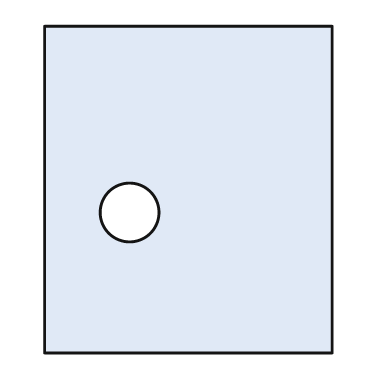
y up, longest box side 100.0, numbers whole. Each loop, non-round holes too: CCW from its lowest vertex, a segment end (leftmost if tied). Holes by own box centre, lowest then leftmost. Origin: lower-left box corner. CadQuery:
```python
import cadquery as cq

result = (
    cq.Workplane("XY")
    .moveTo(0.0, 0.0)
    .lineTo(88.0, 0.0)
    .lineTo(88.0, 100.0)
    .lineTo(0.0, 100.0)
    .close()
    .moveTo(26.0, 43.0)
    .circle(9.0)
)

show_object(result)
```